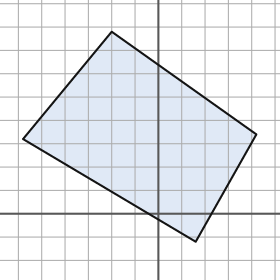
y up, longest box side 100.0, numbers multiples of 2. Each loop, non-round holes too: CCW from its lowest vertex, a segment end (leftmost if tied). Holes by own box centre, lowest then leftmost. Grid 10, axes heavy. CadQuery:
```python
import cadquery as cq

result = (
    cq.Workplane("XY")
    .moveTo(16.0, -12.0)
    .lineTo(42.0, 34.0)
    .lineTo(-20.0, 78.0)
    .lineTo(-58.0, 32.0)
    .close()
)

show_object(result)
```